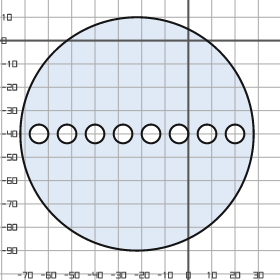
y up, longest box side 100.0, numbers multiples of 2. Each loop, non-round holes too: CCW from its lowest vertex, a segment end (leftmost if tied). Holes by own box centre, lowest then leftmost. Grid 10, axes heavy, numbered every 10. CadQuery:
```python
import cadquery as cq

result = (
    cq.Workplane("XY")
    .moveTo(-22.0, -40.0)
    .circle(50.0)
    .moveTo(-64.0, -40.0)
    .circle(4.0)
    .moveTo(-52.0, -40.0)
    .circle(4.0)
    .moveTo(-40.0, -40.0)
    .circle(4.0)
    .moveTo(-28.0, -40.0)
    .circle(4.0)
    .moveTo(-16.0, -40.0)
    .circle(4.0)
    .moveTo(-4.0, -40.0)
    .circle(4.0)
    .moveTo(8.0, -40.0)
    .circle(4.0)
    .moveTo(20.0, -40.0)
    .circle(4.0)
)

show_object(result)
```